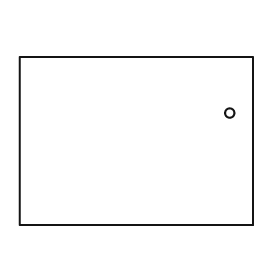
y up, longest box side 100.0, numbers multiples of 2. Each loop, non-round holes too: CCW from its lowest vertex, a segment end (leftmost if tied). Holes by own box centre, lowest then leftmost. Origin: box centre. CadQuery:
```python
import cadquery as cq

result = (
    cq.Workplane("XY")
    .moveTo(-50.0, -36.0)
    .lineTo(50.0, -36.0)
    .lineTo(50.0, 36.0)
    .lineTo(-50.0, 36.0)
    .close()
    .moveTo(40.0, 12.0)
    .circle(2.0)
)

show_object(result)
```